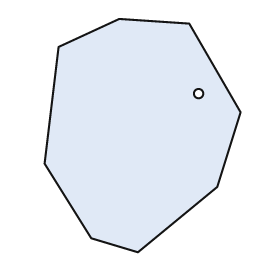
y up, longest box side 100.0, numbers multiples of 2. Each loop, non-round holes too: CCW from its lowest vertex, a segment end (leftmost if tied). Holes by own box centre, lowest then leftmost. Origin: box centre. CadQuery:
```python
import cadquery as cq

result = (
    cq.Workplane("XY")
    .moveTo(-2.0, -50.0)
    .lineTo(32.0, -22.0)
    .lineTo(42.0, 10.0)
    .lineTo(20.0, 48.0)
    .lineTo(-10.0, 50.0)
    .lineTo(-36.0, 38.0)
    .lineTo(-42.0, -12.0)
    .lineTo(-22.0, -44.0)
    .close()
    .moveTo(24.0, 18.0)
    .circle(2.0)
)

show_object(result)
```